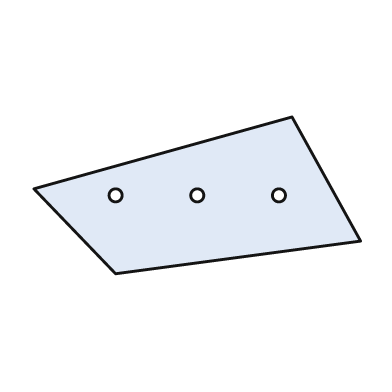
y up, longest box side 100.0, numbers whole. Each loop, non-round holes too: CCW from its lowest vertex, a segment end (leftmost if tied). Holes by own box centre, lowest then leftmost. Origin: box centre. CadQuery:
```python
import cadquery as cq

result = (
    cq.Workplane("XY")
    .moveTo(-25.0, -24.0)
    .lineTo(50.0, -14.0)
    .lineTo(29.0, 24.0)
    .lineTo(-50.0, 2.0)
    .close()
    .moveTo(-25.0, 0.0)
    .circle(2.0)
    .moveTo(0.0, 0.0)
    .circle(2.0)
    .moveTo(25.0, 0.0)
    .circle(2.0)
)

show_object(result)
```